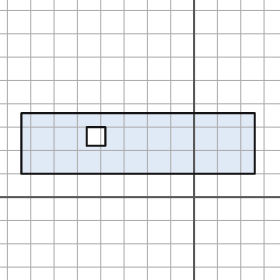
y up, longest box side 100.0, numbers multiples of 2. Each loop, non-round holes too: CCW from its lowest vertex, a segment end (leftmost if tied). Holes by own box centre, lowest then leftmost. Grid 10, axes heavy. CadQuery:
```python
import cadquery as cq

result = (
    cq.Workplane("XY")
    .moveTo(-74.0, 10.0)
    .lineTo(26.0, 10.0)
    .lineTo(26.0, 36.0)
    .lineTo(-74.0, 36.0)
    .close()
    .moveTo(-46.0, 22.0)
    .lineTo(-38.0, 22.0)
    .lineTo(-38.0, 30.0)
    .lineTo(-46.0, 30.0)
    .close()
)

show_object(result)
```